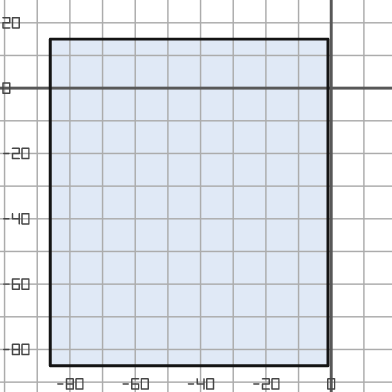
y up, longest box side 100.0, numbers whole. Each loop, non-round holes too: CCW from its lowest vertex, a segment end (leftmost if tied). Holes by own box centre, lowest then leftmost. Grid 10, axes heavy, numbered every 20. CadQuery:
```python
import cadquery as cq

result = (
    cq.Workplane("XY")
    .moveTo(-86.0, -85.0)
    .lineTo(-1.0, -85.0)
    .lineTo(-1.0, 15.0)
    .lineTo(-86.0, 15.0)
    .close()
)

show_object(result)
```